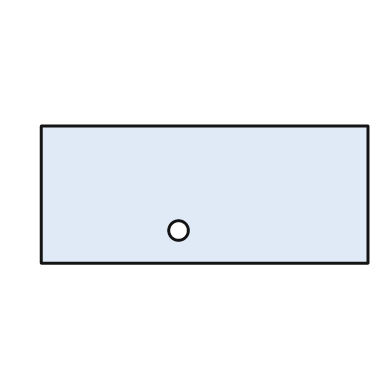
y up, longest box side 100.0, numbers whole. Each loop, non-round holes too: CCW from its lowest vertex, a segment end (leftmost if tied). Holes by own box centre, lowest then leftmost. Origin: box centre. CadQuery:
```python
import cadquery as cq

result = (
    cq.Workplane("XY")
    .moveTo(-50.0, -21.0)
    .lineTo(50.0, -21.0)
    .lineTo(50.0, 21.0)
    .lineTo(-50.0, 21.0)
    .close()
    .moveTo(-8.0, -11.0)
    .circle(3.0)
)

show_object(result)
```